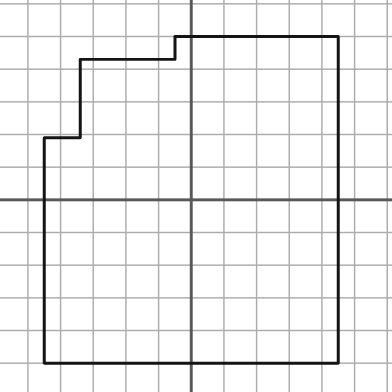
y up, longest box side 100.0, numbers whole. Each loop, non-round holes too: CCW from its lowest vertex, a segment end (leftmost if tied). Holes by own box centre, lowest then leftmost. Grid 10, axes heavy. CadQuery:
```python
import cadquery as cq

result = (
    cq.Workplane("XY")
    .moveTo(-45.0, -50.0)
    .lineTo(45.0, -50.0)
    .lineTo(45.0, 50.0)
    .lineTo(-5.0, 50.0)
    .lineTo(-5.0, 43.0)
    .lineTo(-34.0, 43.0)
    .lineTo(-34.0, 19.0)
    .lineTo(-45.0, 19.0)
    .close()
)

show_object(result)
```